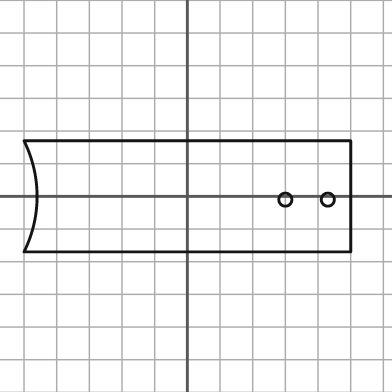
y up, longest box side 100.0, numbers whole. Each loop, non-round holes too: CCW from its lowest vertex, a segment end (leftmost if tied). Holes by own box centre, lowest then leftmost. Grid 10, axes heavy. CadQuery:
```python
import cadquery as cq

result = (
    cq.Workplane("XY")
    .moveTo(-50.0, -17.0)
    .lineTo(50.0, -17.0)
    .lineTo(50.0, 17.0)
    .lineTo(-50.0, 17.0)
    .threePointArc((-46.0, 0.0), (-50.0, -17.0))
    .close()
    .moveTo(30.0, -1.0)
    .circle(2.0)
    .moveTo(43.0, -1.0)
    .circle(2.0)
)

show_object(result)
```